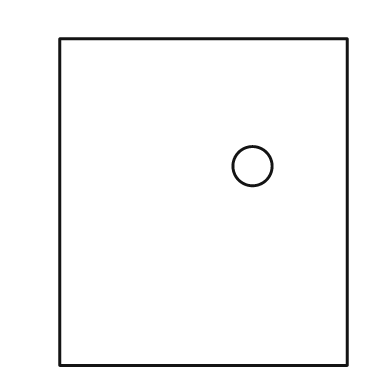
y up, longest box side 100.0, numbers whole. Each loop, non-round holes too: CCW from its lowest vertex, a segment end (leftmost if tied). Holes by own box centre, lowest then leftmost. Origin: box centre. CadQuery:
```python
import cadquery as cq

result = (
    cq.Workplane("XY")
    .moveTo(-44.0, -50.0)
    .lineTo(44.0, -50.0)
    .lineTo(44.0, 50.0)
    .lineTo(-44.0, 50.0)
    .close()
    .moveTo(15.0, 11.0)
    .circle(6.0)
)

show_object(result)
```